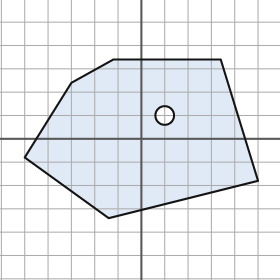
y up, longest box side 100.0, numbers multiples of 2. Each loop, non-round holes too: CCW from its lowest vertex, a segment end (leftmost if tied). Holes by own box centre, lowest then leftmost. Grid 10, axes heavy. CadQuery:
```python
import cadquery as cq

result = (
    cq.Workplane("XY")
    .moveTo(-14.0, -34.0)
    .lineTo(50.0, -18.0)
    .lineTo(34.0, 34.0)
    .lineTo(-12.0, 34.0)
    .lineTo(-30.0, 24.0)
    .lineTo(-50.0, -8.0)
    .close()
    .moveTo(10.0, 10.0)
    .circle(4.0)
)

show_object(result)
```